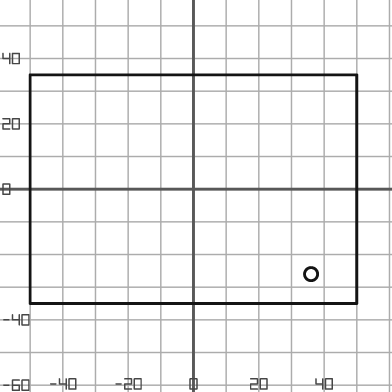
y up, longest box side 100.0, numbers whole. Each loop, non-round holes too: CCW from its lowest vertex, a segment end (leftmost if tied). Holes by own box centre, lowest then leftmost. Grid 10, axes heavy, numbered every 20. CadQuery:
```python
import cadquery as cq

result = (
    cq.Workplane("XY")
    .moveTo(-50.0, -35.0)
    .lineTo(50.0, -35.0)
    .lineTo(50.0, 35.0)
    .lineTo(-50.0, 35.0)
    .close()
    .moveTo(36.0, -26.0)
    .circle(2.0)
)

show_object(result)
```